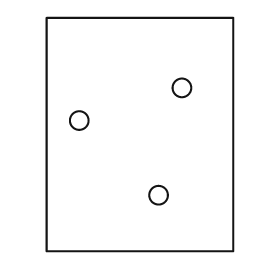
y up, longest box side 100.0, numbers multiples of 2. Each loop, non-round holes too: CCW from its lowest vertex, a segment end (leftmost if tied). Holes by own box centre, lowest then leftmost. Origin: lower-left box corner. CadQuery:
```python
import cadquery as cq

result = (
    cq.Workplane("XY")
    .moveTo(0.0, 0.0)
    .lineTo(80.0, 0.0)
    .lineTo(80.0, 100.0)
    .lineTo(0.0, 100.0)
    .close()
    .moveTo(48.0, 24.0)
    .circle(4.0)
    .moveTo(14.0, 56.0)
    .circle(4.0)
    .moveTo(58.0, 70.0)
    .circle(4.0)
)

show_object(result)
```